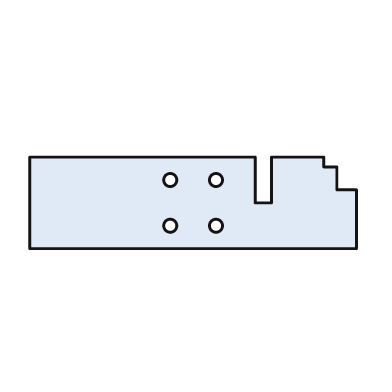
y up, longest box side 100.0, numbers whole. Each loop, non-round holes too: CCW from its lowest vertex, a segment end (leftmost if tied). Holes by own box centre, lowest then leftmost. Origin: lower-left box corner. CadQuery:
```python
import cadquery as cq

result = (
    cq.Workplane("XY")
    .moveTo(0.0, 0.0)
    .lineTo(100.0, 0.0)
    .lineTo(100.0, 18.0)
    .lineTo(94.0, 18.0)
    .lineTo(94.0, 25.0)
    .lineTo(90.0, 25.0)
    .lineTo(90.0, 28.0)
    .lineTo(74.0, 28.0)
    .lineTo(74.0, 14.0)
    .lineTo(69.0, 14.0)
    .lineTo(69.0, 28.0)
    .lineTo(0.0, 28.0)
    .close()
    .moveTo(43.0, 7.0)
    .circle(2.0)
    .moveTo(57.0, 7.0)
    .circle(2.0)
    .moveTo(43.0, 21.0)
    .circle(2.0)
    .moveTo(57.0, 21.0)
    .circle(2.0)
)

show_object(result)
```